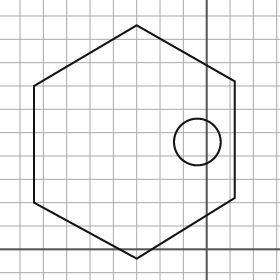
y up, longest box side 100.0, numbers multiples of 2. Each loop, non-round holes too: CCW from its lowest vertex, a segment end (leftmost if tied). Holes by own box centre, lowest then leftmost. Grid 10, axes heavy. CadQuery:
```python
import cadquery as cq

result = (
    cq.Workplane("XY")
    .moveTo(-30.0, -4.0)
    .lineTo(12.0, 22.0)
    .lineTo(12.0, 72.0)
    .lineTo(-30.0, 96.0)
    .lineTo(-74.0, 70.0)
    .lineTo(-74.0, 20.0)
    .close()
    .moveTo(-4.0, 46.0)
    .circle(10.0)
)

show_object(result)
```